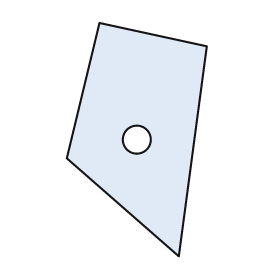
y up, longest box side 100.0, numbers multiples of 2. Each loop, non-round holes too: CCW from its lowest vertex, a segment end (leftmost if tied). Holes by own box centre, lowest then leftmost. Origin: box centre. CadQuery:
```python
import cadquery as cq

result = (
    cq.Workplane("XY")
    .moveTo(18.0, -50.0)
    .lineTo(30.0, 40.0)
    .lineTo(-16.0, 50.0)
    .lineTo(-30.0, -8.0)
    .close()
    .moveTo(0.0, 0.0)
    .circle(6.0)
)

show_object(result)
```